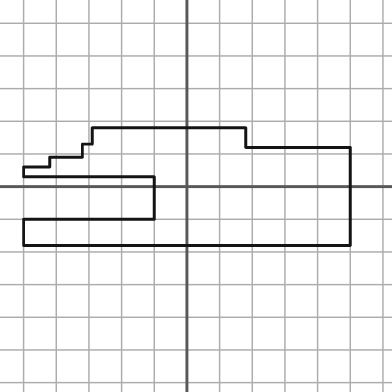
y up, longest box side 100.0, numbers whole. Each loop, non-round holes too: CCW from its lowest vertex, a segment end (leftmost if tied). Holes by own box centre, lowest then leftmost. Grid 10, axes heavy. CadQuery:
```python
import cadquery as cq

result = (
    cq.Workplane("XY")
    .moveTo(-50.0, -18.0)
    .lineTo(50.0, -18.0)
    .lineTo(50.0, 12.0)
    .lineTo(18.0, 12.0)
    .lineTo(18.0, 18.0)
    .lineTo(-29.0, 18.0)
    .lineTo(-29.0, 13.0)
    .lineTo(-32.0, 13.0)
    .lineTo(-32.0, 9.0)
    .lineTo(-42.0, 9.0)
    .lineTo(-42.0, 6.0)
    .lineTo(-50.0, 6.0)
    .lineTo(-50.0, 3.0)
    .lineTo(-10.0, 3.0)
    .lineTo(-10.0, -10.0)
    .lineTo(-50.0, -10.0)
    .close()
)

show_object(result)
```